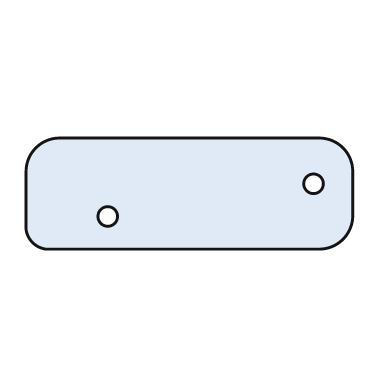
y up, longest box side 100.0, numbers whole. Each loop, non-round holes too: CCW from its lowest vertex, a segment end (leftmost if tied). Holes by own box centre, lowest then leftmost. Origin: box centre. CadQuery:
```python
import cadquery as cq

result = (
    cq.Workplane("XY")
    .moveTo(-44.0, -17.0)
    .lineTo(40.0, -17.0)
    .threePointArc((47.0, -14.0), (50.0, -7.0))
    .lineTo(50.0, 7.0)
    .threePointArc((47.0, 14.0), (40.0, 17.0))
    .lineTo(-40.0, 17.0)
    .threePointArc((-47.0, 14.0), (-50.0, 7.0))
    .lineTo(-50.0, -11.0)
    .threePointArc((-48.0, -15.0), (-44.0, -17.0))
    .close()
    .moveTo(-25.0, -7.0)
    .circle(3.0)
    .moveTo(38.0, 3.0)
    .circle(3.0)
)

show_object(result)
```